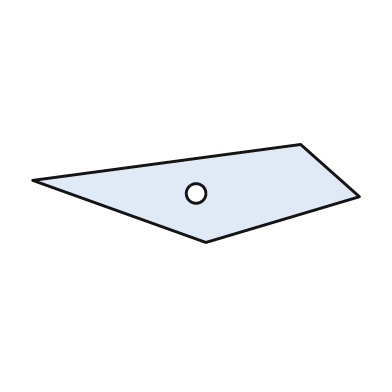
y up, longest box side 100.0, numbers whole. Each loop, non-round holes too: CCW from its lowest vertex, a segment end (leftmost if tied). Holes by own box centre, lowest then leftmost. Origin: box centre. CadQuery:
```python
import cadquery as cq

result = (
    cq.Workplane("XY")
    .moveTo(3.0, -15.0)
    .lineTo(50.0, -1.0)
    .lineTo(32.0, 15.0)
    .lineTo(-50.0, 4.0)
    .close()
    .moveTo(0.0, 0.0)
    .circle(3.0)
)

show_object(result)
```